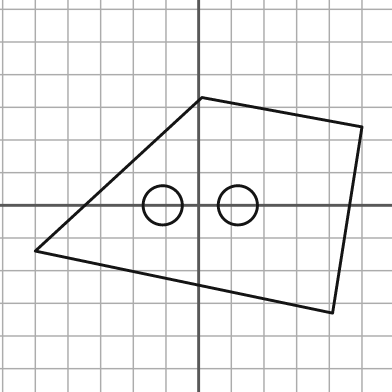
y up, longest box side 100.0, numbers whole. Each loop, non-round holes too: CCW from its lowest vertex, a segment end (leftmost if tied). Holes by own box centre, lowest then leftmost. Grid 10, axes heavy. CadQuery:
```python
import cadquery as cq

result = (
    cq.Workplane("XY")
    .moveTo(41.0, -33.0)
    .lineTo(50.0, 24.0)
    .lineTo(1.0, 33.0)
    .lineTo(-50.0, -14.0)
    .close()
    .moveTo(-11.0, 0.0)
    .circle(6.0)
    .moveTo(12.0, 0.0)
    .circle(6.0)
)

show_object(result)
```